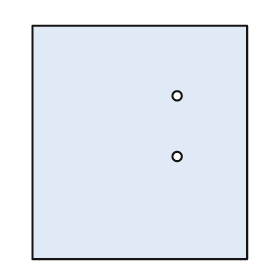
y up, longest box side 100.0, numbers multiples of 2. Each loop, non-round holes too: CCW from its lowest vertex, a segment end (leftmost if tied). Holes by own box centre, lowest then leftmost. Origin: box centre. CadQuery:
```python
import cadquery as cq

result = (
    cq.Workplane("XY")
    .moveTo(-46.0, -50.0)
    .lineTo(46.0, -50.0)
    .lineTo(46.0, 50.0)
    .lineTo(-46.0, 50.0)
    .close()
    .moveTo(16.0, -6.0)
    .circle(2.0)
    .moveTo(16.0, 20.0)
    .circle(2.0)
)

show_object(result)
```